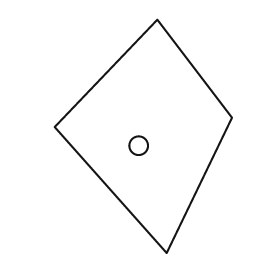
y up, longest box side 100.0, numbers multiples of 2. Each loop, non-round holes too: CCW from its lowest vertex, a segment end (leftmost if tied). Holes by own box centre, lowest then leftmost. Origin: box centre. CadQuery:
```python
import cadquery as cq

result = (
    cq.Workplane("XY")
    .moveTo(10.0, -50.0)
    .lineTo(38.0, 8.0)
    .lineTo(6.0, 50.0)
    .lineTo(-38.0, 4.0)
    .close()
    .moveTo(-2.0, -4.0)
    .circle(4.0)
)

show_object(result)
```